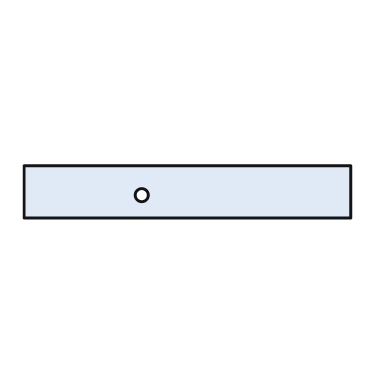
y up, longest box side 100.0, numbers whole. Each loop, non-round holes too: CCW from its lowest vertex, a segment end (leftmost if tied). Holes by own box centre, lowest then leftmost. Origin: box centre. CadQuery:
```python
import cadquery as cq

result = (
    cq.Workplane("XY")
    .moveTo(-50.0, -8.0)
    .lineTo(50.0, -8.0)
    .lineTo(50.0, 8.0)
    .lineTo(-50.0, 8.0)
    .close()
    .moveTo(-14.0, -1.0)
    .circle(2.0)
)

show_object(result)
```